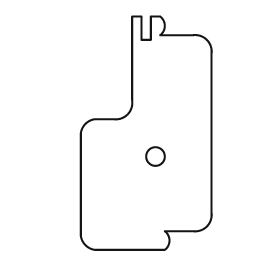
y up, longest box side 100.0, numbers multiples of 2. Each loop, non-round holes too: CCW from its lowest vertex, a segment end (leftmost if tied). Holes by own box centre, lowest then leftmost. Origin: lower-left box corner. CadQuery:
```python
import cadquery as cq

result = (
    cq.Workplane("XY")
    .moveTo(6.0, 0.0)
    .lineTo(36.0, 0.0)
    .threePointArc((38.0, 4.0), (36.0, 8.0))
    .lineTo(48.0, 8.0)
    .threePointArc((54.0, 10.0), (56.0, 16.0))
    .lineTo(56.0, 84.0)
    .threePointArc((54.0, 90.0), (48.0, 92.0))
    .lineTo(34.0, 92.0)
    .threePointArc((36.0, 96.0), (34.0, 100.0))
    .lineTo(30.0, 100.0)
    .lineTo(30.0, 90.0)
    .lineTo(26.0, 90.0)
    .lineTo(26.0, 100.0)
    .lineTo(22.0, 100.0)
    .lineTo(22.0, 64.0)
    .threePointArc((20.0, 58.0), (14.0, 56.0))
    .lineTo(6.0, 56.0)
    .threePointArc((2.0, 54.0), (0.0, 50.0))
    .lineTo(0.0, 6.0)
    .threePointArc((2.0, 2.0), (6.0, 0.0))
    .close()
    .moveTo(32.0, 40.0)
    .circle(4.0)
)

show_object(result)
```